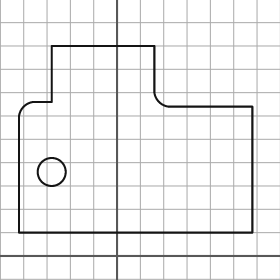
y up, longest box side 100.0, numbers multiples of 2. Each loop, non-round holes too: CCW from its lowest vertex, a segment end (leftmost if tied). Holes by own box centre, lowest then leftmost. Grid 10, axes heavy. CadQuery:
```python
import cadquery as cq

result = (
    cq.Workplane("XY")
    .moveTo(-42.0, 10.0)
    .lineTo(58.0, 10.0)
    .lineTo(58.0, 64.0)
    .lineTo(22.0, 64.0)
    .threePointArc((18.0, 66.0), (16.0, 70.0))
    .lineTo(16.0, 90.0)
    .lineTo(-28.0, 90.0)
    .lineTo(-28.0, 66.0)
    .lineTo(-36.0, 66.0)
    .threePointArc((-40.0, 64.0), (-42.0, 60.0))
    .close()
    .moveTo(-28.0, 36.0)
    .circle(6.0)
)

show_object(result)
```